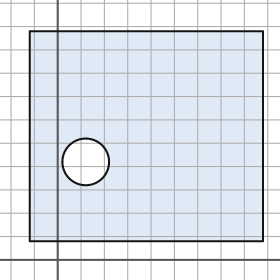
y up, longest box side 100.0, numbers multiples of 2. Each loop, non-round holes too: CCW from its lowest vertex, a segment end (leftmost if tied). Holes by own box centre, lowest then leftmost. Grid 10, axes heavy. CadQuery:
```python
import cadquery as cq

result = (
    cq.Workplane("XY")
    .moveTo(-12.0, 8.0)
    .lineTo(88.0, 8.0)
    .lineTo(88.0, 98.0)
    .lineTo(-12.0, 98.0)
    .close()
    .moveTo(12.0, 42.0)
    .circle(10.0)
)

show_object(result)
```